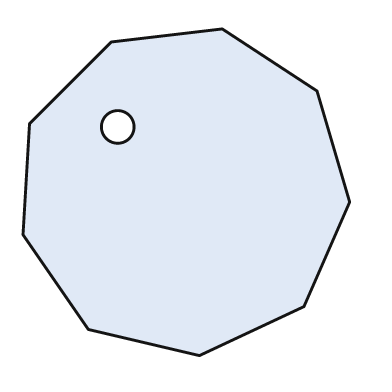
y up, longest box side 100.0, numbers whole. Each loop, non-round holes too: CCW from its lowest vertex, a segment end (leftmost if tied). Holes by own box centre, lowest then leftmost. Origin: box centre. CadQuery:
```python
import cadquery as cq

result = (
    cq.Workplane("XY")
    .moveTo(4.0, -50.0)
    .lineTo(36.0, -35.0)
    .lineTo(50.0, -3.0)
    .lineTo(40.0, 31.0)
    .lineTo(11.0, 50.0)
    .lineTo(-23.0, 46.0)
    .lineTo(-48.0, 21.0)
    .lineTo(-50.0, -13.0)
    .lineTo(-30.0, -42.0)
    .close()
    .moveTo(-21.0, 20.0)
    .circle(5.0)
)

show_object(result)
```